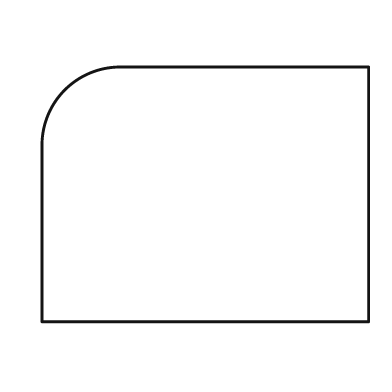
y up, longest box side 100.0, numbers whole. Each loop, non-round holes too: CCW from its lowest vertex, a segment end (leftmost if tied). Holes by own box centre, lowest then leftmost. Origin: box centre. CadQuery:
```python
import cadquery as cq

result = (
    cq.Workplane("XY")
    .moveTo(-50.0, -39.0)
    .lineTo(50.0, -39.0)
    .lineTo(50.0, 39.0)
    .lineTo(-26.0, 39.0)
    .threePointArc((-43.0, 32.0), (-50.0, 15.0))
    .close()
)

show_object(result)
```